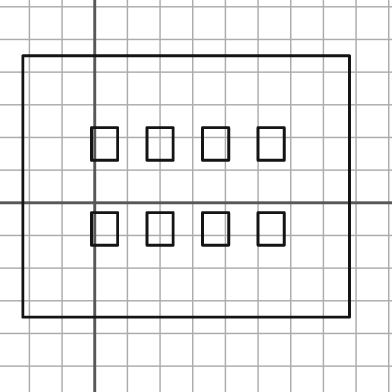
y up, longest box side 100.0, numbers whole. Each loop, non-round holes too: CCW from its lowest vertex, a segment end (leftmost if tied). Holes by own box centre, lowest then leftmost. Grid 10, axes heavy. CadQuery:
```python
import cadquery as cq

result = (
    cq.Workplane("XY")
    .moveTo(-22.0, -35.0)
    .lineTo(78.0, -35.0)
    .lineTo(78.0, 45.0)
    .lineTo(-22.0, 45.0)
    .close()
    .moveTo(-1.0, -13.0)
    .lineTo(7.0, -13.0)
    .lineTo(7.0, -3.0)
    .lineTo(-1.0, -3.0)
    .close()
    .moveTo(16.0, -13.0)
    .lineTo(24.0, -13.0)
    .lineTo(24.0, -3.0)
    .lineTo(16.0, -3.0)
    .close()
    .moveTo(33.0, -13.0)
    .lineTo(41.0, -13.0)
    .lineTo(41.0, -3.0)
    .lineTo(33.0, -3.0)
    .close()
    .moveTo(50.0, -13.0)
    .lineTo(58.0, -13.0)
    .lineTo(58.0, -3.0)
    .lineTo(50.0, -3.0)
    .close()
    .moveTo(-1.0, 13.0)
    .lineTo(7.0, 13.0)
    .lineTo(7.0, 23.0)
    .lineTo(-1.0, 23.0)
    .close()
    .moveTo(16.0, 13.0)
    .lineTo(24.0, 13.0)
    .lineTo(24.0, 23.0)
    .lineTo(16.0, 23.0)
    .close()
    .moveTo(33.0, 13.0)
    .lineTo(41.0, 13.0)
    .lineTo(41.0, 23.0)
    .lineTo(33.0, 23.0)
    .close()
    .moveTo(50.0, 13.0)
    .lineTo(58.0, 13.0)
    .lineTo(58.0, 23.0)
    .lineTo(50.0, 23.0)
    .close()
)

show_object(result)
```